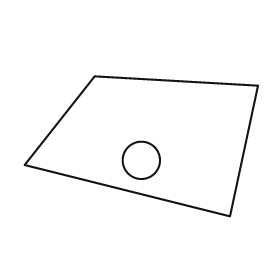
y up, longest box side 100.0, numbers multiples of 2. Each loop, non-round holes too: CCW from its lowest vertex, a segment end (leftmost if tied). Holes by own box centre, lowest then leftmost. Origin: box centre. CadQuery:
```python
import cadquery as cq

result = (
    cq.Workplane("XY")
    .moveTo(38.0, -30.0)
    .lineTo(50.0, 26.0)
    .lineTo(-20.0, 30.0)
    .lineTo(-50.0, -8.0)
    .close()
    .moveTo(0.0, -6.0)
    .circle(8.0)
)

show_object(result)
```